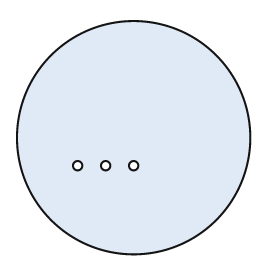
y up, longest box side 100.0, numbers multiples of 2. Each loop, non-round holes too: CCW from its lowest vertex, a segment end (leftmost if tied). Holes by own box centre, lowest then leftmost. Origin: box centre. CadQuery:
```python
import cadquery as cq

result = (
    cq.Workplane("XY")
    .moveTo(0.0, 0.0)
    .circle(50.0)
    .moveTo(-24.0, -12.0)
    .circle(2.0)
    .moveTo(-12.0, -12.0)
    .circle(2.0)
    .moveTo(0.0, -12.0)
    .circle(2.0)
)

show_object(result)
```